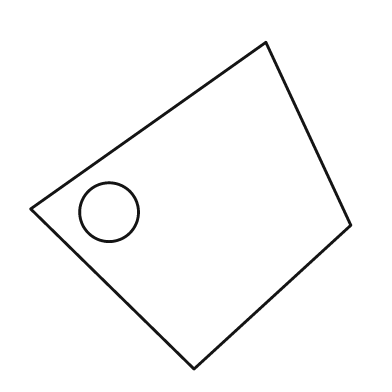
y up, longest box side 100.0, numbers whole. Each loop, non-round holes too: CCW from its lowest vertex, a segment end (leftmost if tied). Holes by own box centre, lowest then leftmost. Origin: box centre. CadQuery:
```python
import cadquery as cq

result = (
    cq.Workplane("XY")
    .moveTo(1.0, -50.0)
    .lineTo(49.0, -6.0)
    .lineTo(23.0, 50.0)
    .lineTo(-49.0, -1.0)
    .close()
    .moveTo(-25.0, -2.0)
    .circle(9.0)
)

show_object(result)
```